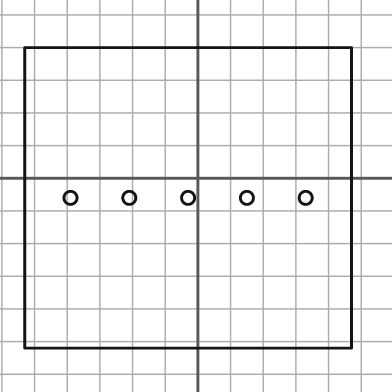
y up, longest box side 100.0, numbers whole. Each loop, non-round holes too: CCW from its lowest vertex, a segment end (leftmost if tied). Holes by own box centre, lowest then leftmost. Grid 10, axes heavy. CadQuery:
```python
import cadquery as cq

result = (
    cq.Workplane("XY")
    .moveTo(-53.0, -52.0)
    .lineTo(47.0, -52.0)
    .lineTo(47.0, 40.0)
    .lineTo(-53.0, 40.0)
    .close()
    .moveTo(-39.0, -6.0)
    .circle(2.0)
    .moveTo(-21.0, -6.0)
    .circle(2.0)
    .moveTo(-3.0, -6.0)
    .circle(2.0)
    .moveTo(15.0, -6.0)
    .circle(2.0)
    .moveTo(33.0, -6.0)
    .circle(2.0)
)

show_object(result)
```